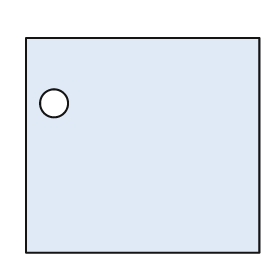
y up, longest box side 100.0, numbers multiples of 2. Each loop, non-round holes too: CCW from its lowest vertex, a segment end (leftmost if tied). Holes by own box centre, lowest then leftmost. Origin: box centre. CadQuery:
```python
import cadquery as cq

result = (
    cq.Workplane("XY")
    .moveTo(-50.0, -46.0)
    .lineTo(50.0, -46.0)
    .lineTo(50.0, 46.0)
    .lineTo(-50.0, 46.0)
    .close()
    .moveTo(-38.0, 18.0)
    .circle(6.0)
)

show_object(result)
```